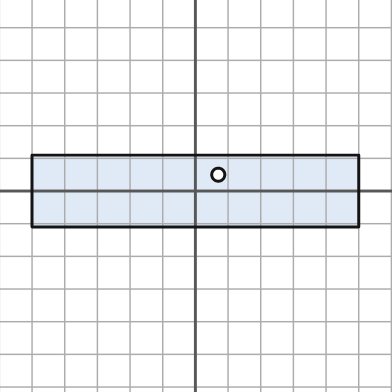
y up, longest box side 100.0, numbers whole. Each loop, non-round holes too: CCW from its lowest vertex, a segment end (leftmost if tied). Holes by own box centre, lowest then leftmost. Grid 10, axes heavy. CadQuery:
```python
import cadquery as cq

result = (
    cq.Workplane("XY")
    .moveTo(-50.0, -11.0)
    .lineTo(50.0, -11.0)
    .lineTo(50.0, 11.0)
    .lineTo(-50.0, 11.0)
    .close()
    .moveTo(7.0, 5.0)
    .circle(2.0)
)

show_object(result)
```